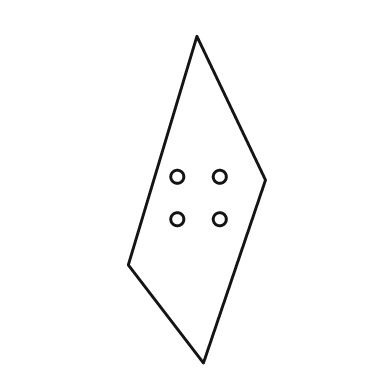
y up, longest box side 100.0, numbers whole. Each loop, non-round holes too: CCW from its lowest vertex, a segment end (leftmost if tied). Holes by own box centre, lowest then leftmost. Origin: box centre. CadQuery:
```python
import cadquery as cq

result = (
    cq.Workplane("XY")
    .moveTo(2.0, -50.0)
    .lineTo(21.0, 6.0)
    .lineTo(0.0, 50.0)
    .lineTo(-21.0, -20.0)
    .close()
    .moveTo(-6.0, -6.0)
    .circle(2.0)
    .moveTo(7.0, -6.0)
    .circle(2.0)
    .moveTo(-6.0, 7.0)
    .circle(2.0)
    .moveTo(7.0, 7.0)
    .circle(2.0)
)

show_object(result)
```